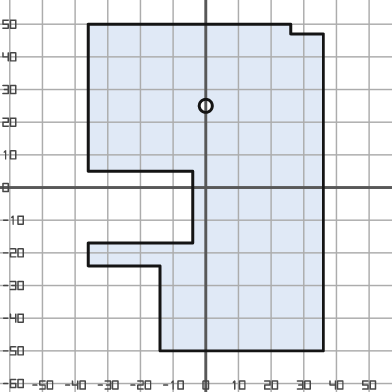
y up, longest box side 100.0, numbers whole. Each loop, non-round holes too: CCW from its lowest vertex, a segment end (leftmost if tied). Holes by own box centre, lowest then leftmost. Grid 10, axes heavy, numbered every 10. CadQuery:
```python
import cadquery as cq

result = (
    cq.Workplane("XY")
    .moveTo(-14.0, -50.0)
    .lineTo(36.0, -50.0)
    .lineTo(36.0, 47.0)
    .lineTo(26.0, 47.0)
    .lineTo(26.0, 50.0)
    .lineTo(-36.0, 50.0)
    .lineTo(-36.0, 5.0)
    .lineTo(-4.0, 5.0)
    .lineTo(-4.0, -17.0)
    .lineTo(-36.0, -17.0)
    .lineTo(-36.0, -24.0)
    .lineTo(-14.0, -24.0)
    .close()
    .moveTo(0.0, 25.0)
    .circle(2.0)
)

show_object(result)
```